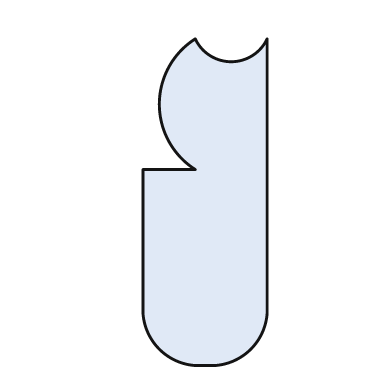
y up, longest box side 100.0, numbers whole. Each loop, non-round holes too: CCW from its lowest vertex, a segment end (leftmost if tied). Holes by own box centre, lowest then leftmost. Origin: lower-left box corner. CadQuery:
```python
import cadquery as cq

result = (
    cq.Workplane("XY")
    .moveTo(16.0, 0.0)
    .lineTo(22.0, 0.0)
    .threePointArc((33.0, 5.0), (38.0, 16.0))
    .lineTo(38.0, 100.0)
    .threePointArc((27.0, 93.0), (16.0, 100.0))
    .threePointArc((5.0, 80.0), (16.0, 60.0))
    .lineTo(0.0, 60.0)
    .lineTo(0.0, 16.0)
    .threePointArc((5.0, 5.0), (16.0, 0.0))
    .close()
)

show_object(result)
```